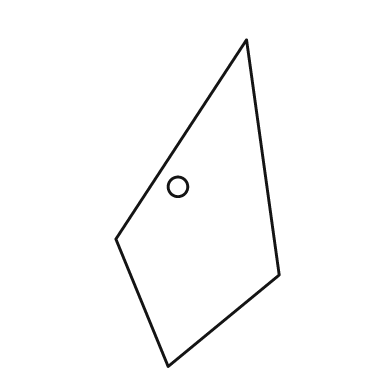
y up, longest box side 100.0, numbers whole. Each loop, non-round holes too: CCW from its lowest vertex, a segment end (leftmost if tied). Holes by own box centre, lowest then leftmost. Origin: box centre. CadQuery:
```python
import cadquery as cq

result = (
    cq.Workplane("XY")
    .moveTo(-9.0, -50.0)
    .lineTo(25.0, -22.0)
    .lineTo(15.0, 50.0)
    .lineTo(-25.0, -11.0)
    .close()
    .moveTo(-6.0, 5.0)
    .circle(3.0)
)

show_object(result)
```